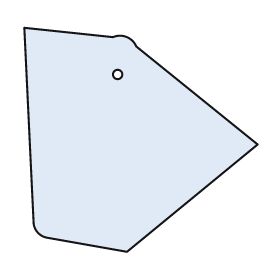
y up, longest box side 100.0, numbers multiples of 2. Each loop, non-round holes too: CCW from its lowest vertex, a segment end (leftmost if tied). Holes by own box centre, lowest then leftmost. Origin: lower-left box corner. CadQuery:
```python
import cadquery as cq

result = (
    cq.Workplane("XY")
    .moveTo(44.0, 0.0)
    .lineTo(100.0, 46.0)
    .lineTo(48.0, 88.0)
    .threePointArc((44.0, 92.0), (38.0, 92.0))
    .lineTo(0.0, 96.0)
    .lineTo(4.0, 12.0)
    .threePointArc((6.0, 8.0), (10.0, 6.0))
    .close()
    .moveTo(40.0, 76.0)
    .circle(2.0)
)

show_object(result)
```